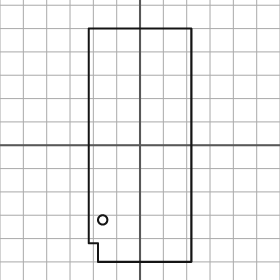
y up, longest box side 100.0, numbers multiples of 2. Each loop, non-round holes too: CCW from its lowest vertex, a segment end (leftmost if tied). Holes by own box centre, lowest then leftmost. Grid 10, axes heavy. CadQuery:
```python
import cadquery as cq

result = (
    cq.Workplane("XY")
    .moveTo(-18.0, -50.0)
    .lineTo(22.0, -50.0)
    .lineTo(22.0, 50.0)
    .lineTo(-22.0, 50.0)
    .lineTo(-22.0, -42.0)
    .lineTo(-18.0, -42.0)
    .close()
    .moveTo(-16.0, -32.0)
    .circle(2.0)
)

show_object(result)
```